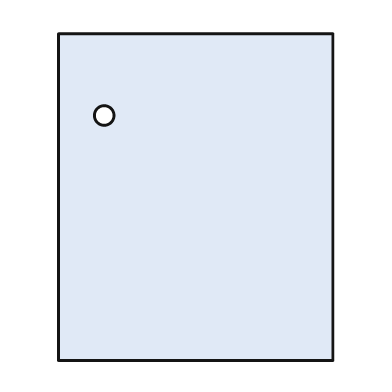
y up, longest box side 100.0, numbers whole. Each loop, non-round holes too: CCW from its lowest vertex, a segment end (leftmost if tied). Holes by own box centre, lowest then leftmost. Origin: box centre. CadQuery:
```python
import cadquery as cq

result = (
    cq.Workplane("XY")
    .moveTo(-42.0, -50.0)
    .lineTo(42.0, -50.0)
    .lineTo(42.0, 50.0)
    .lineTo(-42.0, 50.0)
    .close()
    .moveTo(-28.0, 25.0)
    .circle(3.0)
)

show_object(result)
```